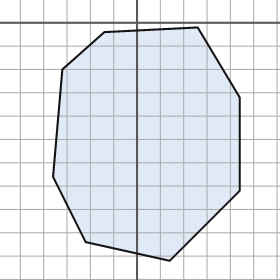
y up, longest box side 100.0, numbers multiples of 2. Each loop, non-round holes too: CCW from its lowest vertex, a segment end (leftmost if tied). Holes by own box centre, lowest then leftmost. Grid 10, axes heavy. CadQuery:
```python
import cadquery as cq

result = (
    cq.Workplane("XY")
    .moveTo(14.0, -102.0)
    .lineTo(44.0, -72.0)
    .lineTo(44.0, -32.0)
    .lineTo(26.0, -2.0)
    .lineTo(-14.0, -4.0)
    .lineTo(-32.0, -20.0)
    .lineTo(-36.0, -66.0)
    .lineTo(-22.0, -94.0)
    .close()
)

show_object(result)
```